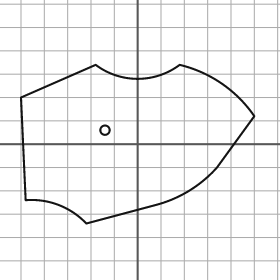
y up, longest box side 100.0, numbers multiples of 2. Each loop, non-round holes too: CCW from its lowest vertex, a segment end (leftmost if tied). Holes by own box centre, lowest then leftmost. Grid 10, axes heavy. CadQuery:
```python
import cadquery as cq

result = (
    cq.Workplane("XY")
    .moveTo(-22.0, -34.0)
    .lineTo(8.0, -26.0)
    .threePointArc((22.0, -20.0), (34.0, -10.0))
    .lineTo(50.0, 12.0)
    .threePointArc((36.0, 26.0), (18.0, 34.0))
    .threePointArc((0.0, 28.0), (-18.0, 34.0))
    .lineTo(-50.0, 20.0)
    .lineTo(-48.0, -24.0)
    .threePointArc((-34.0, -26.0), (-22.0, -34.0))
    .close()
    .moveTo(-14.0, 6.0)
    .circle(2.0)
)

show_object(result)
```